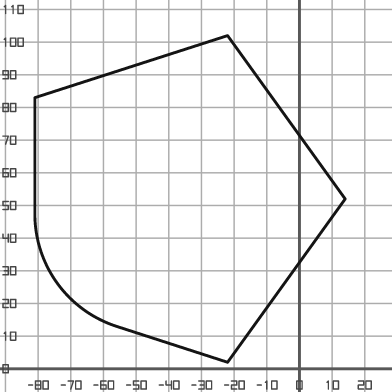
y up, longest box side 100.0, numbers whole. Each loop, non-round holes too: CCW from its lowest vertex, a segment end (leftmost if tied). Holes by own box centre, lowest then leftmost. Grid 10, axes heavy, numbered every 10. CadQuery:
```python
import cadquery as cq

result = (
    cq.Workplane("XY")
    .moveTo(-22.0, 2.0)
    .lineTo(14.0, 52.0)
    .lineTo(-22.0, 102.0)
    .lineTo(-81.0, 83.0)
    .lineTo(-81.0, 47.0)
    .threePointArc((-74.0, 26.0), (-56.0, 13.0))
    .close()
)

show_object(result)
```